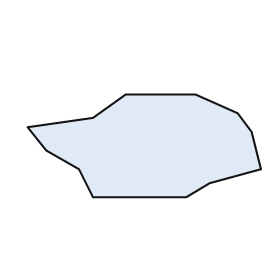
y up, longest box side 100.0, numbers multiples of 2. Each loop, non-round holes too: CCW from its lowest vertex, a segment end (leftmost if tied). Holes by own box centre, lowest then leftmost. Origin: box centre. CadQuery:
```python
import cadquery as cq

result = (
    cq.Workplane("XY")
    .moveTo(-22.0, -22.0)
    .lineTo(18.0, -22.0)
    .lineTo(28.0, -16.0)
    .lineTo(50.0, -10.0)
    .lineTo(46.0, 6.0)
    .lineTo(40.0, 14.0)
    .lineTo(22.0, 22.0)
    .lineTo(-8.0, 22.0)
    .lineTo(-22.0, 12.0)
    .lineTo(-50.0, 8.0)
    .lineTo(-42.0, -2.0)
    .lineTo(-28.0, -10.0)
    .close()
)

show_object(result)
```